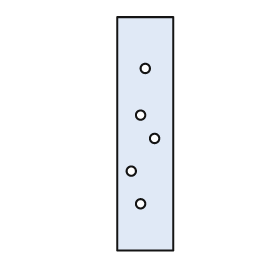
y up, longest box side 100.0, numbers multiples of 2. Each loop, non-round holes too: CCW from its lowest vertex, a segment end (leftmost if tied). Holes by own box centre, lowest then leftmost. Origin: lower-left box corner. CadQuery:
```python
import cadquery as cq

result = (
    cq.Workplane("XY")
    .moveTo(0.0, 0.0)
    .lineTo(24.0, 0.0)
    .lineTo(24.0, 100.0)
    .lineTo(0.0, 100.0)
    .close()
    .moveTo(10.0, 20.0)
    .circle(2.0)
    .moveTo(6.0, 34.0)
    .circle(2.0)
    .moveTo(16.0, 48.0)
    .circle(2.0)
    .moveTo(10.0, 58.0)
    .circle(2.0)
    .moveTo(12.0, 78.0)
    .circle(2.0)
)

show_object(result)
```